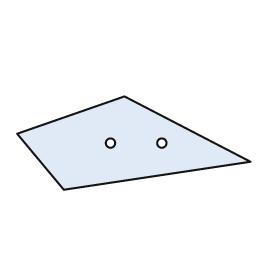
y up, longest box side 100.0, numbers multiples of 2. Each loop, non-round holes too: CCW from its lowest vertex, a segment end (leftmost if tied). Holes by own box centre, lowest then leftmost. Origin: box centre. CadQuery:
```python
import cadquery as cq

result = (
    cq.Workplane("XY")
    .moveTo(-30.0, -20.0)
    .lineTo(50.0, -8.0)
    .lineTo(-4.0, 20.0)
    .lineTo(-50.0, 4.0)
    .close()
    .moveTo(-10.0, 0.0)
    .circle(2.0)
    .moveTo(12.0, 0.0)
    .circle(2.0)
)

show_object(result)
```